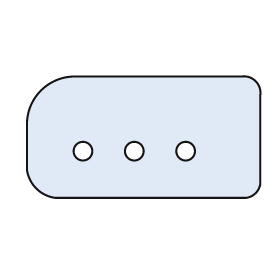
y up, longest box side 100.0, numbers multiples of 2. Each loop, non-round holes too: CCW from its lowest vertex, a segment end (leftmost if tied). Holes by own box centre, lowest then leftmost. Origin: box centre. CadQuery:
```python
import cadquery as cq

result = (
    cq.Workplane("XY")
    .moveTo(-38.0, -26.0)
    .lineTo(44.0, -26.0)
    .threePointArc((48.0, -24.0), (50.0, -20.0))
    .lineTo(50.0, 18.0)
    .threePointArc((48.0, 24.0), (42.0, 26.0))
    .lineTo(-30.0, 26.0)
    .threePointArc((-44.0, 20.0), (-50.0, 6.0))
    .lineTo(-50.0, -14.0)
    .threePointArc((-46.0, -22.0), (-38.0, -26.0))
    .close()
    .moveTo(-26.0, -6.0)
    .circle(4.0)
    .moveTo(-4.0, -6.0)
    .circle(4.0)
    .moveTo(18.0, -6.0)
    .circle(4.0)
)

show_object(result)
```